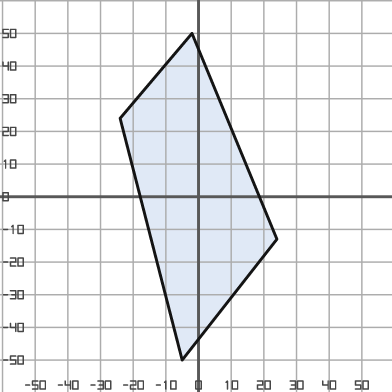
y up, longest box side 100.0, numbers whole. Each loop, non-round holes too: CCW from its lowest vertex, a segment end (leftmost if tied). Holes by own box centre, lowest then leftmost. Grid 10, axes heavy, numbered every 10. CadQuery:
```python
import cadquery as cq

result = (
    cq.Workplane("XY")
    .moveTo(-5.0, -50.0)
    .lineTo(24.0, -13.0)
    .lineTo(-2.0, 50.0)
    .lineTo(-24.0, 24.0)
    .close()
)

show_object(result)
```